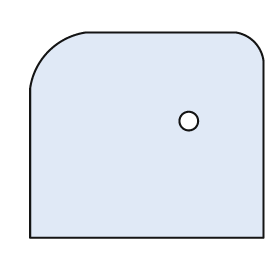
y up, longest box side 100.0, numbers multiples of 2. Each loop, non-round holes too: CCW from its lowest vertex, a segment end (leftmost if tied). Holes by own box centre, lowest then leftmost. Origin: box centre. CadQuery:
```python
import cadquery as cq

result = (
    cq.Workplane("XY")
    .moveTo(-50.0, -44.0)
    .lineTo(50.0, -44.0)
    .lineTo(50.0, 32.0)
    .threePointArc((46.0, 40.0), (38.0, 44.0))
    .lineTo(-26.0, 44.0)
    .threePointArc((-42.0, 36.0), (-50.0, 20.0))
    .close()
    .moveTo(18.0, 6.0)
    .circle(4.0)
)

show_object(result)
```